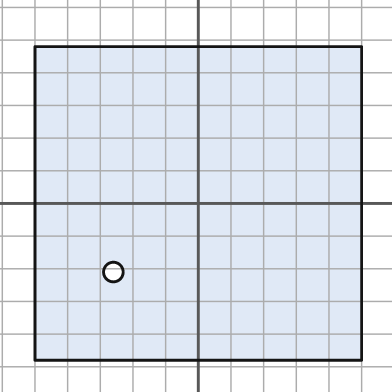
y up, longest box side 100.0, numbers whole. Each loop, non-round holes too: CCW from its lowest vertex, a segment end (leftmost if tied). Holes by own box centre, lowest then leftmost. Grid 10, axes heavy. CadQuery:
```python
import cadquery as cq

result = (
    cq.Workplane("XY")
    .moveTo(-50.0, -48.0)
    .lineTo(50.0, -48.0)
    .lineTo(50.0, 48.0)
    .lineTo(-50.0, 48.0)
    .close()
    .moveTo(-26.0, -21.0)
    .circle(3.0)
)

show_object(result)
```